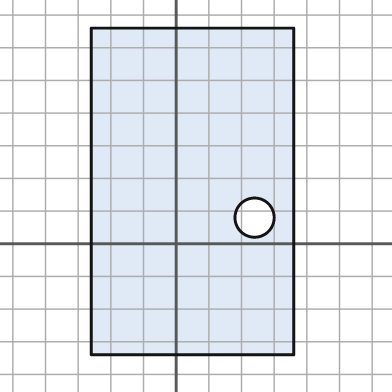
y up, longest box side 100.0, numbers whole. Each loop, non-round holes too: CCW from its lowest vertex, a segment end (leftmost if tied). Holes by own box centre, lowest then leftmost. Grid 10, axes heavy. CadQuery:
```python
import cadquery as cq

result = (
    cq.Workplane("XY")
    .moveTo(-26.0, -34.0)
    .lineTo(36.0, -34.0)
    .lineTo(36.0, 66.0)
    .lineTo(-26.0, 66.0)
    .close()
    .moveTo(24.0, 8.0)
    .circle(6.0)
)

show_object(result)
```